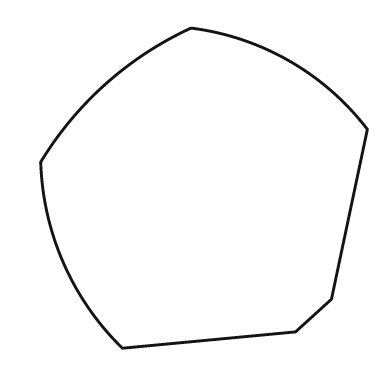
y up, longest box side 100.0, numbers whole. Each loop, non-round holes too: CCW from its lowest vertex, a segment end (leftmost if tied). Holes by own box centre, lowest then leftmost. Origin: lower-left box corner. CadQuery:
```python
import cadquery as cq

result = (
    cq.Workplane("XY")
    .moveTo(25.0, 0.0)
    .lineTo(78.0, 5.0)
    .lineTo(89.0, 15.0)
    .lineTo(100.0, 67.0)
    .threePointArc((76.0, 88.0), (46.0, 98.0))
    .threePointArc((20.0, 81.0), (0.0, 57.0))
    .threePointArc((7.0, 26.0), (25.0, 0.0))
    .close()
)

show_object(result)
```